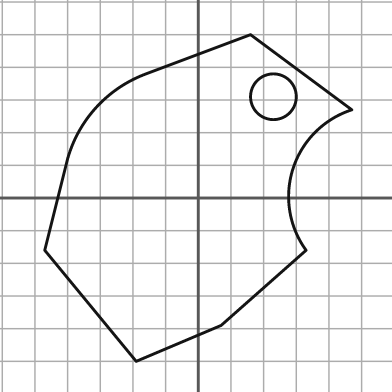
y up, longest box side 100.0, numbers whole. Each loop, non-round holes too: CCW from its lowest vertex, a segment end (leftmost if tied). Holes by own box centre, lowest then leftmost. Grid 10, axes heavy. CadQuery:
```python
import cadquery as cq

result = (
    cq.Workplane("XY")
    .moveTo(-19.0, -50.0)
    .lineTo(7.0, -39.0)
    .lineTo(33.0, -16.0)
    .threePointArc((29.0, 9.0), (47.0, 27.0))
    .lineTo(16.0, 50.0)
    .lineTo(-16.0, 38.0)
    .threePointArc((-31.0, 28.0), (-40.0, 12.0))
    .lineTo(-47.0, -16.0)
    .close()
    .moveTo(23.0, 31.0)
    .circle(7.0)
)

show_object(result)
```